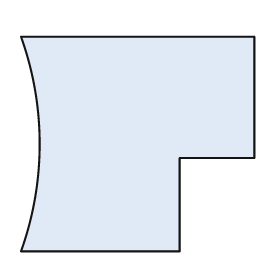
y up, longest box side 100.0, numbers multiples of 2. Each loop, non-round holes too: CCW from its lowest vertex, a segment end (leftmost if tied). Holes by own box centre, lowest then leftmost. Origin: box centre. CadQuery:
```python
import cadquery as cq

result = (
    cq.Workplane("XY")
    .moveTo(-50.0, -46.0)
    .lineTo(18.0, -46.0)
    .lineTo(18.0, -6.0)
    .lineTo(50.0, -6.0)
    .lineTo(50.0, 46.0)
    .lineTo(-50.0, 46.0)
    .threePointArc((-42.0, 0.0), (-50.0, -46.0))
    .close()
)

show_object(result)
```